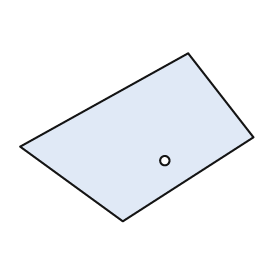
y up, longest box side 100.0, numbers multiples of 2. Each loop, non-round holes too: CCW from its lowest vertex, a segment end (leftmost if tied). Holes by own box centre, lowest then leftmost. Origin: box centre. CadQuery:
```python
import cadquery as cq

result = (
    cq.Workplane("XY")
    .moveTo(-6.0, -36.0)
    .lineTo(50.0, 0.0)
    .lineTo(22.0, 36.0)
    .lineTo(-50.0, -4.0)
    .close()
    .moveTo(12.0, -10.0)
    .circle(2.0)
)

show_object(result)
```